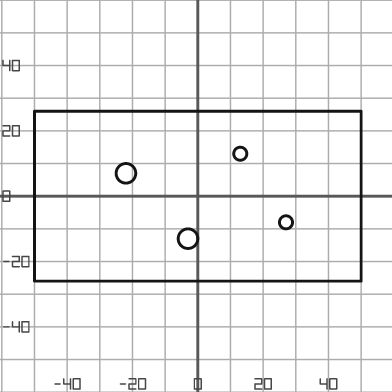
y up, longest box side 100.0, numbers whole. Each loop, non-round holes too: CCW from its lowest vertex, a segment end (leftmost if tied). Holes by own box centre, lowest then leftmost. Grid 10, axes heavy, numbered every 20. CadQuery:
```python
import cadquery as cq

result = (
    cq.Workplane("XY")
    .moveTo(-50.0, -26.0)
    .lineTo(50.0, -26.0)
    .lineTo(50.0, 26.0)
    .lineTo(-50.0, 26.0)
    .close()
    .moveTo(-3.0, -13.0)
    .circle(3.0)
    .moveTo(27.0, -8.0)
    .circle(2.0)
    .moveTo(-22.0, 7.0)
    .circle(3.0)
    .moveTo(13.0, 13.0)
    .circle(2.0)
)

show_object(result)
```